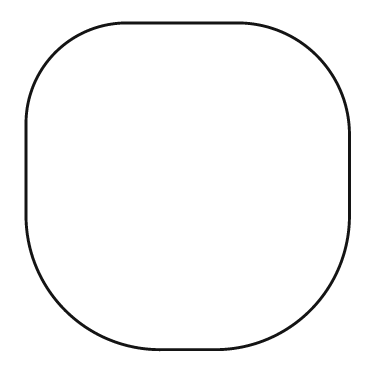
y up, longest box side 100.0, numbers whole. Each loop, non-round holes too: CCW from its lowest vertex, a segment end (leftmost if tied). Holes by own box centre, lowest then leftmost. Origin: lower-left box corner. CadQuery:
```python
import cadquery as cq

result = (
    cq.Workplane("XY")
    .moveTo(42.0, 0.0)
    .lineTo(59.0, 0.0)
    .threePointArc((87.0, 12.0), (99.0, 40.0))
    .lineTo(99.0, 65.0)
    .threePointArc((89.0, 90.0), (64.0, 100.0))
    .lineTo(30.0, 100.0)
    .threePointArc((9.0, 91.0), (0.0, 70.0))
    .lineTo(0.0, 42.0)
    .threePointArc((12.0, 12.0), (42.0, 0.0))
    .close()
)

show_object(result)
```